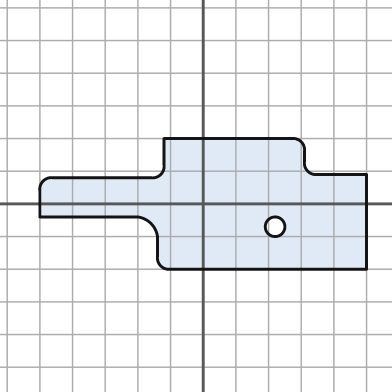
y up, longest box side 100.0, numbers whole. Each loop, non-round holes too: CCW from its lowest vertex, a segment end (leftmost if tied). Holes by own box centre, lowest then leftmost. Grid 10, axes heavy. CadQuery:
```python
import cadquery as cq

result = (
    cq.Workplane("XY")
    .moveTo(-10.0, -20.0)
    .lineTo(50.0, -20.0)
    .lineTo(50.0, 9.0)
    .lineTo(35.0, 9.0)
    .threePointArc((32.0, 10.0), (31.0, 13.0))
    .lineTo(31.0, 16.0)
    .threePointArc((30.0, 19.0), (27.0, 20.0))
    .lineTo(-12.0, 20.0)
    .lineTo(-12.0, 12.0)
    .threePointArc((-13.0, 9.0), (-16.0, 8.0))
    .lineTo(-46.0, 8.0)
    .threePointArc((-49.0, 7.0), (-50.0, 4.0))
    .lineTo(-50.0, -4.0)
    .lineTo(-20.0, -4.0)
    .threePointArc((-16.0, -6.0), (-14.0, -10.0))
    .lineTo(-14.0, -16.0)
    .threePointArc((-13.0, -19.0), (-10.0, -20.0))
    .close()
    .moveTo(22.0, -7.0)
    .circle(3.0)
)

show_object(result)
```